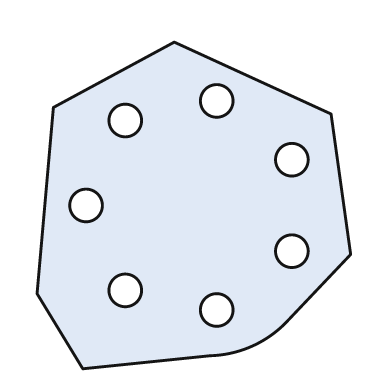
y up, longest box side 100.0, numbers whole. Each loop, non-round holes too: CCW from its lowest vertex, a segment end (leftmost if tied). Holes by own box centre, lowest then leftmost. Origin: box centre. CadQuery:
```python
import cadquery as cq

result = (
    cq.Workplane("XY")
    .moveTo(-34.0, -50.0)
    .lineTo(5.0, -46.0)
    .threePointArc((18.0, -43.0), (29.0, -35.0))
    .lineTo(48.0, -15.0)
    .lineTo(42.0, 28.0)
    .lineTo(-6.0, 50.0)
    .lineTo(-43.0, 30.0)
    .lineTo(-48.0, -27.0)
    .close()
    .moveTo(7.0, -32.0)
    .circle(5.0)
    .moveTo(-21.0, -26.0)
    .circle(5.0)
    .moveTo(30.0, -14.0)
    .circle(5.0)
    .moveTo(-33.0, 0.0)
    .circle(5.0)
    .moveTo(30.0, 14.0)
    .circle(5.0)
    .moveTo(-21.0, 26.0)
    .circle(5.0)
    .moveTo(7.0, 32.0)
    .circle(5.0)
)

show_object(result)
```